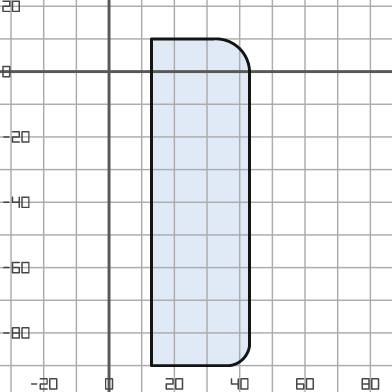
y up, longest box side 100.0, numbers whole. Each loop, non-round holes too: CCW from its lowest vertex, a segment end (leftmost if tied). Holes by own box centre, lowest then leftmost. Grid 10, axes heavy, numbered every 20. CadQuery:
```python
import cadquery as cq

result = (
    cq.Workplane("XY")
    .moveTo(13.0, -90.0)
    .lineTo(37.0, -90.0)
    .threePointArc((41.0, -88.0), (43.0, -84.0))
    .lineTo(43.0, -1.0)
    .threePointArc((40.0, 7.0), (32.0, 10.0))
    .lineTo(13.0, 10.0)
    .close()
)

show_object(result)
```